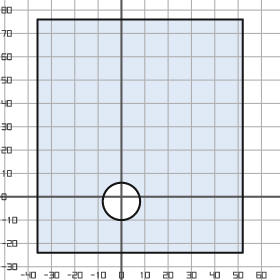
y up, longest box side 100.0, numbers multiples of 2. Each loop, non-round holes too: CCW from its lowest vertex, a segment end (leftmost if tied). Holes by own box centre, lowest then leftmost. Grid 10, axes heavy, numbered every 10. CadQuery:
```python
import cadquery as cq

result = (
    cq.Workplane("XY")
    .moveTo(-36.0, -24.0)
    .lineTo(52.0, -24.0)
    .lineTo(52.0, 76.0)
    .lineTo(-36.0, 76.0)
    .close()
    .moveTo(0.0, -2.0)
    .circle(8.0)
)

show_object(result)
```